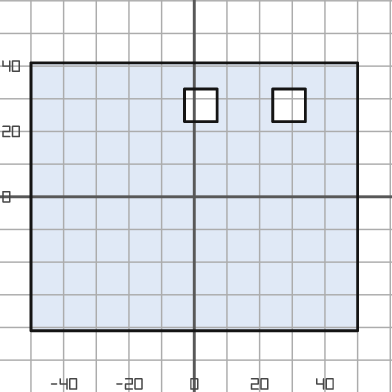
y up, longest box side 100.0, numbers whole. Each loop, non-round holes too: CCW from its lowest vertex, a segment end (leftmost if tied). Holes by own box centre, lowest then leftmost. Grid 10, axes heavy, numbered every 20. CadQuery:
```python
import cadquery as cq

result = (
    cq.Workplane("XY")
    .moveTo(-50.0, -41.0)
    .lineTo(50.0, -41.0)
    .lineTo(50.0, 41.0)
    .lineTo(-50.0, 41.0)
    .close()
    .moveTo(-3.0, 23.0)
    .lineTo(7.0, 23.0)
    .lineTo(7.0, 33.0)
    .lineTo(-3.0, 33.0)
    .close()
    .moveTo(24.0, 23.0)
    .lineTo(34.0, 23.0)
    .lineTo(34.0, 33.0)
    .lineTo(24.0, 33.0)
    .close()
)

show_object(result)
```